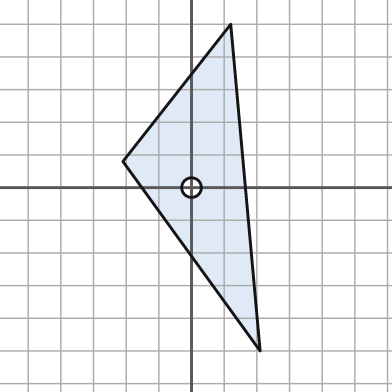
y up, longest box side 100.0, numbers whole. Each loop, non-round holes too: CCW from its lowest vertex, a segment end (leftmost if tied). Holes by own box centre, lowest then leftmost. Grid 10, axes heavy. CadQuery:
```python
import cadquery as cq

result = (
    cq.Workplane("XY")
    .moveTo(21.0, -50.0)
    .lineTo(12.0, 50.0)
    .lineTo(-21.0, 8.0)
    .close()
    .moveTo(0.0, 0.0)
    .circle(3.0)
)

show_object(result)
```